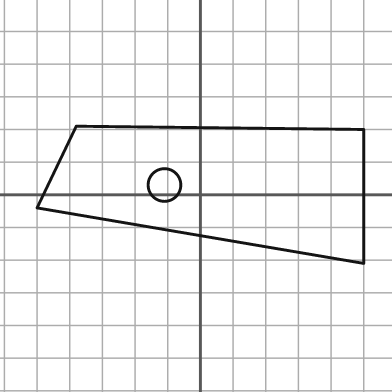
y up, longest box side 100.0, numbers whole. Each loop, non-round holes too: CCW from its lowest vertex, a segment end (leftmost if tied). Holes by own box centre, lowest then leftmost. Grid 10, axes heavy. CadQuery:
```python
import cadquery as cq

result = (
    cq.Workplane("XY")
    .moveTo(50.0, -21.0)
    .lineTo(50.0, 20.0)
    .lineTo(-38.0, 21.0)
    .lineTo(-50.0, -4.0)
    .close()
    .moveTo(-11.0, 3.0)
    .circle(5.0)
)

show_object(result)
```